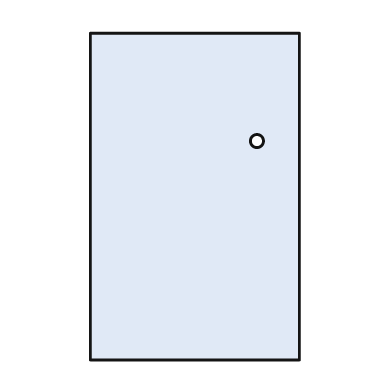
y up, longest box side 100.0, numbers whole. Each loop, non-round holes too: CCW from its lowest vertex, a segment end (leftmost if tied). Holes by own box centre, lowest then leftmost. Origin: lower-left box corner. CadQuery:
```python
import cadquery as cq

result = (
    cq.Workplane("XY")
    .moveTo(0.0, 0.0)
    .lineTo(64.0, 0.0)
    .lineTo(64.0, 100.0)
    .lineTo(0.0, 100.0)
    .close()
    .moveTo(51.0, 67.0)
    .circle(2.0)
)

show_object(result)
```